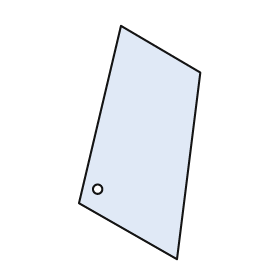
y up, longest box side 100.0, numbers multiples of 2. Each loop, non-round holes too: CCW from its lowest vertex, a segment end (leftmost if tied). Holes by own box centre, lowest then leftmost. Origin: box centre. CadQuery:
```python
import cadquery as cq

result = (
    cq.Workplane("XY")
    .moveTo(16.0, -50.0)
    .lineTo(26.0, 30.0)
    .lineTo(-8.0, 50.0)
    .lineTo(-26.0, -26.0)
    .close()
    .moveTo(-18.0, -20.0)
    .circle(2.0)
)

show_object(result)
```